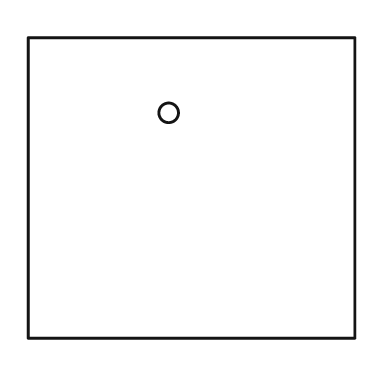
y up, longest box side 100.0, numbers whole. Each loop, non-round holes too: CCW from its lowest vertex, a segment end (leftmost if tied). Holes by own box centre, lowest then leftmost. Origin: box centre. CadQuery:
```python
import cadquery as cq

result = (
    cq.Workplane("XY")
    .moveTo(-50.0, -46.0)
    .lineTo(50.0, -46.0)
    .lineTo(50.0, 46.0)
    .lineTo(-50.0, 46.0)
    .close()
    .moveTo(-7.0, 23.0)
    .circle(3.0)
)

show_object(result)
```